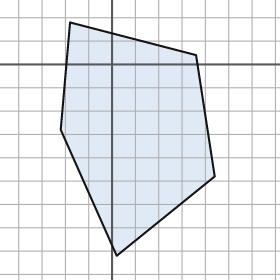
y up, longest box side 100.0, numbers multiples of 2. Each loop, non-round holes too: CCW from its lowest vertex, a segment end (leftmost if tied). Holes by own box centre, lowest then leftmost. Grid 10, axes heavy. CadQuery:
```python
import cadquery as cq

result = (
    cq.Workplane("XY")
    .moveTo(2.0, -82.0)
    .lineTo(44.0, -48.0)
    .lineTo(36.0, 4.0)
    .lineTo(-18.0, 18.0)
    .lineTo(-22.0, -28.0)
    .close()
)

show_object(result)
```